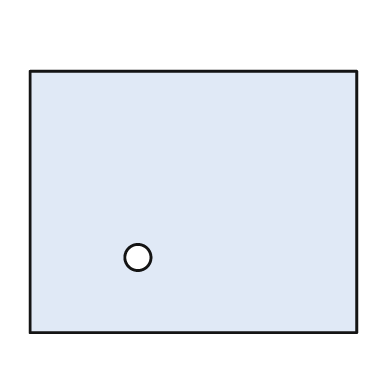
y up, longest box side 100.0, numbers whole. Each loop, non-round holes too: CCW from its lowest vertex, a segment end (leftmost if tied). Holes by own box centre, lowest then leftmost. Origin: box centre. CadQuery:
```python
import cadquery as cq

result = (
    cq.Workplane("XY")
    .moveTo(-50.0, -40.0)
    .lineTo(50.0, -40.0)
    .lineTo(50.0, 40.0)
    .lineTo(-50.0, 40.0)
    .close()
    .moveTo(-17.0, -17.0)
    .circle(4.0)
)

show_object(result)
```